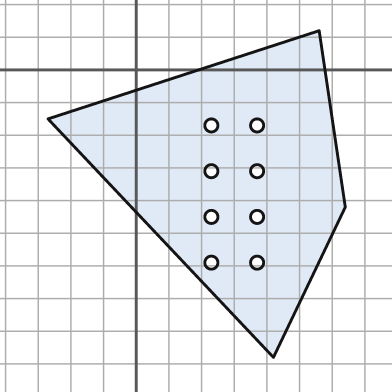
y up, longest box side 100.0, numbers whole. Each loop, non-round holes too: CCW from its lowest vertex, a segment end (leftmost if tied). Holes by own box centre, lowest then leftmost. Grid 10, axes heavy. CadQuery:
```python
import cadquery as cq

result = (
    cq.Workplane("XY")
    .moveTo(42.0, -88.0)
    .lineTo(64.0, -42.0)
    .lineTo(56.0, 12.0)
    .lineTo(-27.0, -15.0)
    .close()
    .moveTo(23.0, -59.0)
    .circle(2.0)
    .moveTo(37.0, -59.0)
    .circle(2.0)
    .moveTo(23.0, -45.0)
    .circle(2.0)
    .moveTo(37.0, -45.0)
    .circle(2.0)
    .moveTo(23.0, -31.0)
    .circle(2.0)
    .moveTo(37.0, -31.0)
    .circle(2.0)
    .moveTo(23.0, -17.0)
    .circle(2.0)
    .moveTo(37.0, -17.0)
    .circle(2.0)
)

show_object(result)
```